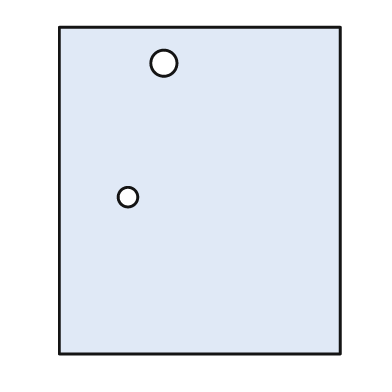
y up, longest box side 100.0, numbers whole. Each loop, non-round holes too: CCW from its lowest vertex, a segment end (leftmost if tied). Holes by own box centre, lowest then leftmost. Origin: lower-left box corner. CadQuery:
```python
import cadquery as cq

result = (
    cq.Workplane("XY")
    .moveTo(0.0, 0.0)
    .lineTo(86.0, 0.0)
    .lineTo(86.0, 100.0)
    .lineTo(0.0, 100.0)
    .close()
    .moveTo(21.0, 48.0)
    .circle(3.0)
    .moveTo(32.0, 89.0)
    .circle(4.0)
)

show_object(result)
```